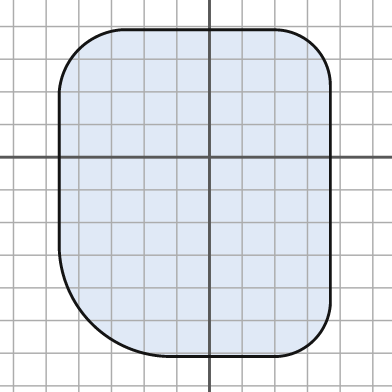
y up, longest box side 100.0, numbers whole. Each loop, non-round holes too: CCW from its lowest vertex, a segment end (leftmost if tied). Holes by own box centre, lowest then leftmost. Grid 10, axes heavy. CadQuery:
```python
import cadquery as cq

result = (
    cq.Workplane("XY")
    .moveTo(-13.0, -61.0)
    .lineTo(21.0, -61.0)
    .threePointArc((32.0, -56.0), (37.0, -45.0))
    .lineTo(37.0, 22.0)
    .threePointArc((32.0, 34.0), (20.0, 39.0))
    .lineTo(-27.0, 39.0)
    .threePointArc((-40.0, 33.0), (-46.0, 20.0))
    .lineTo(-46.0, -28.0)
    .threePointArc((-36.0, -51.0), (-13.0, -61.0))
    .close()
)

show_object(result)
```